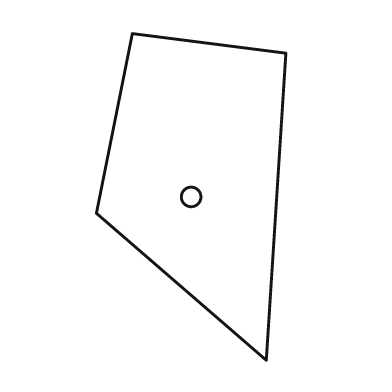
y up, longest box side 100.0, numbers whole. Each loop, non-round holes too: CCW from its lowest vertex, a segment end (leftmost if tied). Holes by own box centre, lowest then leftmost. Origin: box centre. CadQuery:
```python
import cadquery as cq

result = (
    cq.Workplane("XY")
    .moveTo(23.0, -50.0)
    .lineTo(29.0, 44.0)
    .lineTo(-18.0, 50.0)
    .lineTo(-29.0, -5.0)
    .close()
    .moveTo(0.0, 0.0)
    .circle(3.0)
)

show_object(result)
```